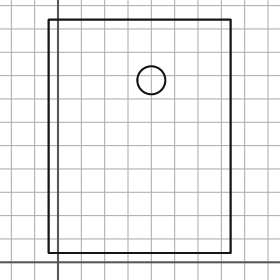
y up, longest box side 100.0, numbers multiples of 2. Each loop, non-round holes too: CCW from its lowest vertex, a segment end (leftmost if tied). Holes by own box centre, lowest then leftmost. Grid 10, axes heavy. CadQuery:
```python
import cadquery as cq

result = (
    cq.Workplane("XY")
    .moveTo(-4.0, 4.0)
    .lineTo(74.0, 4.0)
    .lineTo(74.0, 104.0)
    .lineTo(-4.0, 104.0)
    .close()
    .moveTo(40.0, 78.0)
    .circle(6.0)
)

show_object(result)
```